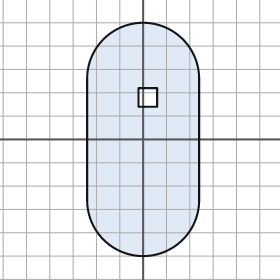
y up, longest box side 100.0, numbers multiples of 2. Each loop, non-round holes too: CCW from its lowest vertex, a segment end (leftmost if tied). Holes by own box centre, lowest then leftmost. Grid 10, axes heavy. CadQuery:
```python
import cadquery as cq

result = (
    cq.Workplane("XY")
    .moveTo(-24.0, -26.0)
    .threePointArc((0.0, -50.0), (24.0, -26.0))
    .lineTo(24.0, 26.0)
    .threePointArc((0.0, 50.0), (-24.0, 26.0))
    .close()
    .moveTo(-2.0, 14.0)
    .lineTo(6.0, 14.0)
    .lineTo(6.0, 22.0)
    .lineTo(-2.0, 22.0)
    .close()
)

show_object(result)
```